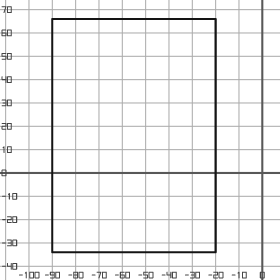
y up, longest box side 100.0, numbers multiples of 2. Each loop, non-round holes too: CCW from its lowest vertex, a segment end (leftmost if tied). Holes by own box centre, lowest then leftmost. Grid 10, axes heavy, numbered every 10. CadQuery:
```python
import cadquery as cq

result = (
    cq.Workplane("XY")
    .moveTo(-90.0, -34.0)
    .lineTo(-20.0, -34.0)
    .lineTo(-20.0, 66.0)
    .lineTo(-90.0, 66.0)
    .close()
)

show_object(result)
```